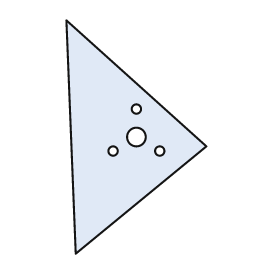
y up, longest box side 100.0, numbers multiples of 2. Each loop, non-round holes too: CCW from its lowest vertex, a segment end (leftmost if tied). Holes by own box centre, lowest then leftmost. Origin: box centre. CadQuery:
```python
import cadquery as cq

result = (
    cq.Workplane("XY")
    .moveTo(-26.0, -50.0)
    .lineTo(30.0, -4.0)
    .lineTo(-30.0, 50.0)
    .close()
    .moveTo(-10.0, -6.0)
    .circle(2.0)
    .moveTo(10.0, -6.0)
    .circle(2.0)
    .moveTo(0.0, 0.0)
    .circle(4.0)
    .moveTo(0.0, 12.0)
    .circle(2.0)
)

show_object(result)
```